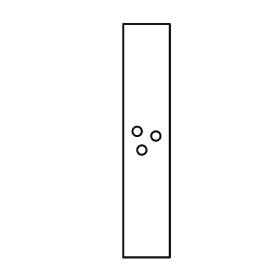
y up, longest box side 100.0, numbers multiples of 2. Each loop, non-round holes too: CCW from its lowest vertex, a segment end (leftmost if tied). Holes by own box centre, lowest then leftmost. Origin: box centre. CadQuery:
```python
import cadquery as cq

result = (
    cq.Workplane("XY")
    .moveTo(-10.0, -50.0)
    .lineTo(10.0, -50.0)
    .lineTo(10.0, 50.0)
    .lineTo(-10.0, 50.0)
    .close()
    .moveTo(-2.0, -4.0)
    .circle(2.0)
    .moveTo(4.0, 2.0)
    .circle(2.0)
    .moveTo(-4.0, 4.0)
    .circle(2.0)
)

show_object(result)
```